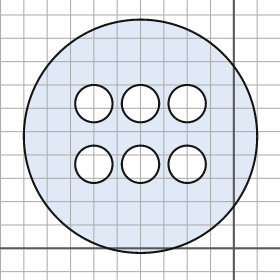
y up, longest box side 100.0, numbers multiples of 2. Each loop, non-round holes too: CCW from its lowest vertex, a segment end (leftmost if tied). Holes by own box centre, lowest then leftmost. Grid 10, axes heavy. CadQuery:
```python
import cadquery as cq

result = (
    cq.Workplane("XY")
    .moveTo(-40.0, 48.0)
    .circle(50.0)
    .moveTo(-60.0, 36.0)
    .circle(8.0)
    .moveTo(-40.0, 36.0)
    .circle(8.0)
    .moveTo(-20.0, 36.0)
    .circle(8.0)
    .moveTo(-60.0, 62.0)
    .circle(8.0)
    .moveTo(-40.0, 62.0)
    .circle(8.0)
    .moveTo(-20.0, 62.0)
    .circle(8.0)
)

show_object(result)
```